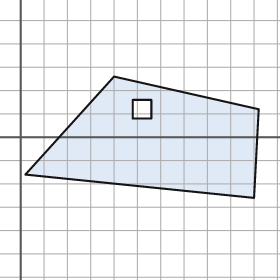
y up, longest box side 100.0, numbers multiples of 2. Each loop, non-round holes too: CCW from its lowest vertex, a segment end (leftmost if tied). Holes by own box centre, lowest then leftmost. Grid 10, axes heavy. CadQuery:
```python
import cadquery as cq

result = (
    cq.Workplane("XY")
    .moveTo(100.0, -26.0)
    .lineTo(102.0, 12.0)
    .lineTo(40.0, 26.0)
    .lineTo(2.0, -16.0)
    .close()
    .moveTo(48.0, 8.0)
    .lineTo(56.0, 8.0)
    .lineTo(56.0, 16.0)
    .lineTo(48.0, 16.0)
    .close()
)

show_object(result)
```